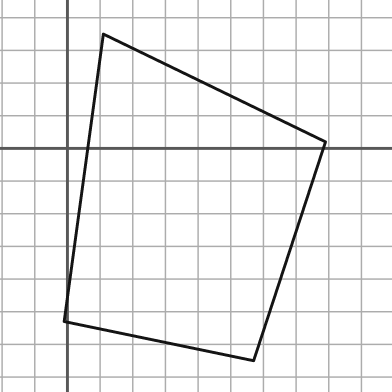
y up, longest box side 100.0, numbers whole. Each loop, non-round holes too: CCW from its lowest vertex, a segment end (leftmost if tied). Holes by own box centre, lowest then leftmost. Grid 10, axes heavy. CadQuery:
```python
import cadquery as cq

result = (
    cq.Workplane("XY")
    .moveTo(57.0, -65.0)
    .lineTo(79.0, 2.0)
    .lineTo(11.0, 35.0)
    .lineTo(-1.0, -53.0)
    .close()
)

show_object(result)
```